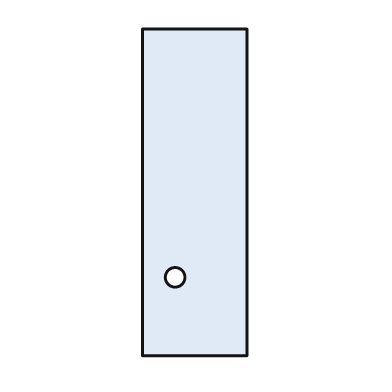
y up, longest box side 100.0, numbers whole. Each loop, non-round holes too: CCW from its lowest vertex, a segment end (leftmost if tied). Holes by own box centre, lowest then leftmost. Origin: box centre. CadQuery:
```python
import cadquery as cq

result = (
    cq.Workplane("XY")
    .moveTo(-16.0, -50.0)
    .lineTo(16.0, -50.0)
    .lineTo(16.0, 50.0)
    .lineTo(-16.0, 50.0)
    .close()
    .moveTo(-6.0, -26.0)
    .circle(3.0)
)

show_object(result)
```